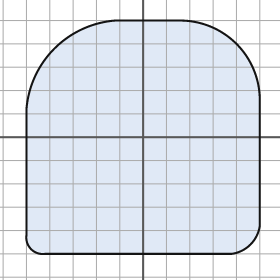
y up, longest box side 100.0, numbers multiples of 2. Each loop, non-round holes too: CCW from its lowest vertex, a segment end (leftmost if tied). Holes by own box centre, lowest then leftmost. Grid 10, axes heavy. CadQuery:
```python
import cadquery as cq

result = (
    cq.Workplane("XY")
    .moveTo(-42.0, -50.0)
    .lineTo(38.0, -50.0)
    .threePointArc((46.0, -46.0), (50.0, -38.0))
    .lineTo(50.0, 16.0)
    .threePointArc((40.0, 40.0), (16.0, 50.0))
    .lineTo(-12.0, 50.0)
    .threePointArc((-38.0, 38.0), (-50.0, 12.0))
    .lineTo(-50.0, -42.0)
    .threePointArc((-48.0, -48.0), (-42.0, -50.0))
    .close()
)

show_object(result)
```